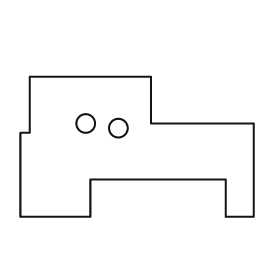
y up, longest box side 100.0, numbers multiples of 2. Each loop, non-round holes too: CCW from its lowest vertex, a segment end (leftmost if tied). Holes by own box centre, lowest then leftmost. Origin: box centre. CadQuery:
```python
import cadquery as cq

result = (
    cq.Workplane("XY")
    .moveTo(-50.0, -30.0)
    .lineTo(-20.0, -30.0)
    .lineTo(-20.0, -14.0)
    .lineTo(38.0, -14.0)
    .lineTo(38.0, -30.0)
    .lineTo(50.0, -30.0)
    .lineTo(50.0, 10.0)
    .lineTo(6.0, 10.0)
    .lineTo(6.0, 30.0)
    .lineTo(-46.0, 30.0)
    .lineTo(-46.0, 6.0)
    .lineTo(-50.0, 6.0)
    .close()
    .moveTo(-8.0, 8.0)
    .circle(4.0)
    .moveTo(-22.0, 10.0)
    .circle(4.0)
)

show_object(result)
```